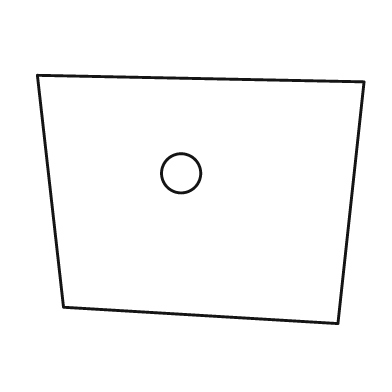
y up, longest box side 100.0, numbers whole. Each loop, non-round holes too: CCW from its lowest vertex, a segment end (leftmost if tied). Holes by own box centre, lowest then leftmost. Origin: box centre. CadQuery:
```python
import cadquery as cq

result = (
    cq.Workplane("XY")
    .moveTo(42.0, -38.0)
    .lineTo(50.0, 36.0)
    .lineTo(-50.0, 38.0)
    .lineTo(-42.0, -33.0)
    .close()
    .moveTo(-6.0, 8.0)
    .circle(6.0)
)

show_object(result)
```